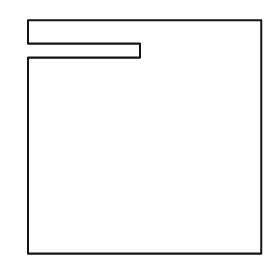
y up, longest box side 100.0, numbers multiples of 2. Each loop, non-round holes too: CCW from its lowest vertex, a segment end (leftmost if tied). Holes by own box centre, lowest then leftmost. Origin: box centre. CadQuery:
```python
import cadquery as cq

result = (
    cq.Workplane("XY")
    .moveTo(-50.0, -50.0)
    .lineTo(50.0, -50.0)
    .lineTo(50.0, 50.0)
    .lineTo(-50.0, 50.0)
    .lineTo(-50.0, 40.0)
    .lineTo(-2.0, 40.0)
    .lineTo(-2.0, 34.0)
    .lineTo(-50.0, 34.0)
    .close()
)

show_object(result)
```